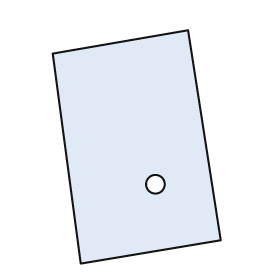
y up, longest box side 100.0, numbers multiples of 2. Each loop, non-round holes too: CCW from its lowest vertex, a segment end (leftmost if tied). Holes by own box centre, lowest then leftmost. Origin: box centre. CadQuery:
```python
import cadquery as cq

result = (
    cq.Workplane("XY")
    .moveTo(-24.0, -50.0)
    .lineTo(36.0, -40.0)
    .lineTo(22.0, 50.0)
    .lineTo(-36.0, 40.0)
    .close()
    .moveTo(8.0, -16.0)
    .circle(4.0)
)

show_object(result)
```